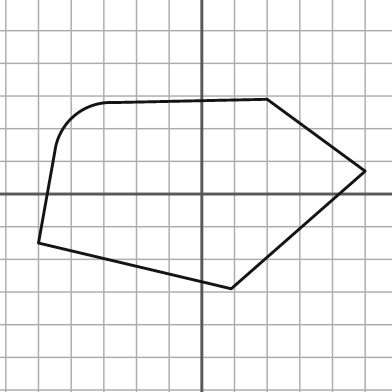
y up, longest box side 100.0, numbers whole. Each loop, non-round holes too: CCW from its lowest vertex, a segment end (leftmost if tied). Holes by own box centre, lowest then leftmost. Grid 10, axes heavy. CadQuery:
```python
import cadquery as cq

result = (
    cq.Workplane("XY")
    .moveTo(9.0, -29.0)
    .lineTo(50.0, 7.0)
    .lineTo(20.0, 29.0)
    .lineTo(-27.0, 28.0)
    .threePointArc((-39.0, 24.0), (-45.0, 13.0))
    .lineTo(-50.0, -15.0)
    .close()
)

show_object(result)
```